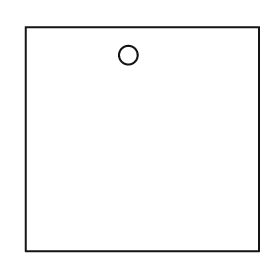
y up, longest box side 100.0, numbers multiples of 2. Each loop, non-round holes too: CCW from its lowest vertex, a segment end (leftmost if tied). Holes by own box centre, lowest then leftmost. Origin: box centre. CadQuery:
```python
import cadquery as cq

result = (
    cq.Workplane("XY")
    .moveTo(-50.0, -48.0)
    .lineTo(50.0, -48.0)
    .lineTo(50.0, 48.0)
    .lineTo(-50.0, 48.0)
    .close()
    .moveTo(-6.0, 36.0)
    .circle(4.0)
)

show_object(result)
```